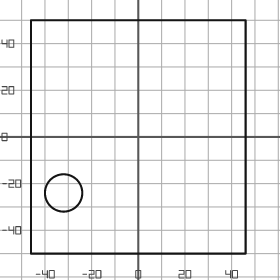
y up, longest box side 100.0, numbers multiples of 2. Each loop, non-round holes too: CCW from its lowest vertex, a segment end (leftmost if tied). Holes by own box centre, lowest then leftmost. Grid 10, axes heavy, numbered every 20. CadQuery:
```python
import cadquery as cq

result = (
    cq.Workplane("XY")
    .moveTo(-46.0, -50.0)
    .lineTo(46.0, -50.0)
    .lineTo(46.0, 50.0)
    .lineTo(-46.0, 50.0)
    .close()
    .moveTo(-32.0, -24.0)
    .circle(8.0)
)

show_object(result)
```